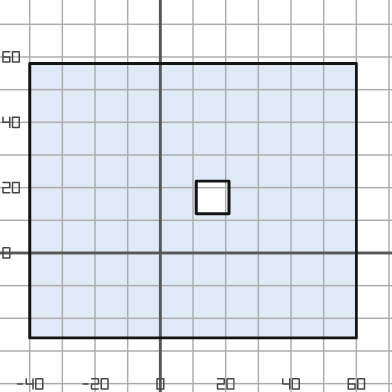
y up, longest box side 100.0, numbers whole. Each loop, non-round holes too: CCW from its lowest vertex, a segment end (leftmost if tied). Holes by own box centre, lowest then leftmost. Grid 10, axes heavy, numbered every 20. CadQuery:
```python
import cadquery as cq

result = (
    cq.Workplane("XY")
    .moveTo(-40.0, -26.0)
    .lineTo(60.0, -26.0)
    .lineTo(60.0, 58.0)
    .lineTo(-40.0, 58.0)
    .close()
    .moveTo(11.0, 12.0)
    .lineTo(21.0, 12.0)
    .lineTo(21.0, 22.0)
    .lineTo(11.0, 22.0)
    .close()
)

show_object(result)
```